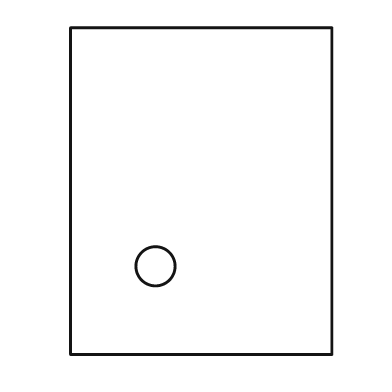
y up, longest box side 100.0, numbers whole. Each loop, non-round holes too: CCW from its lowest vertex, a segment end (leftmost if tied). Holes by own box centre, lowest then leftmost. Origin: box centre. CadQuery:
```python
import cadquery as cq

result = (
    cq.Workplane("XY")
    .moveTo(-40.0, -50.0)
    .lineTo(40.0, -50.0)
    .lineTo(40.0, 50.0)
    .lineTo(-40.0, 50.0)
    .close()
    .moveTo(-14.0, -23.0)
    .circle(6.0)
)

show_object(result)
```